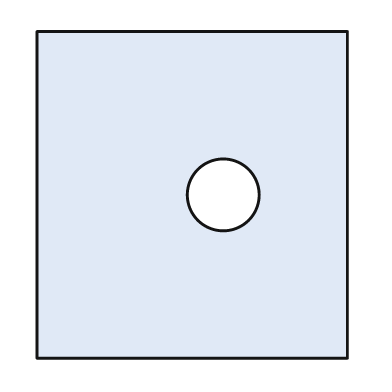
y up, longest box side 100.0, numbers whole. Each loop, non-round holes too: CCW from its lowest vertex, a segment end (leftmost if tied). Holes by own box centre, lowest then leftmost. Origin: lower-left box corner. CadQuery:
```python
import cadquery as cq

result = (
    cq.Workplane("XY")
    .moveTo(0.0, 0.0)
    .lineTo(95.0, 0.0)
    .lineTo(95.0, 100.0)
    .lineTo(0.0, 100.0)
    .close()
    .moveTo(57.0, 50.0)
    .circle(11.0)
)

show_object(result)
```